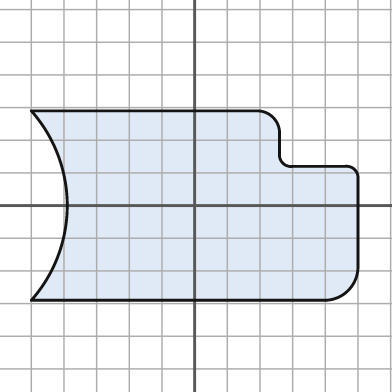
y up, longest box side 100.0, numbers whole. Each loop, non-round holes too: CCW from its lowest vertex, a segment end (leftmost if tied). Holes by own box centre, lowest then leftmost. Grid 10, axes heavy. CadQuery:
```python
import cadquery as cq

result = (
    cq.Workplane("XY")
    .moveTo(-50.0, -29.0)
    .lineTo(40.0, -29.0)
    .threePointArc((47.0, -26.0), (50.0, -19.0))
    .lineTo(50.0, 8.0)
    .threePointArc((49.0, 11.0), (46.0, 12.0))
    .lineTo(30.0, 12.0)
    .threePointArc((27.0, 13.0), (26.0, 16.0))
    .lineTo(26.0, 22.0)
    .threePointArc((24.0, 27.0), (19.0, 29.0))
    .lineTo(-50.0, 29.0)
    .threePointArc((-39.0, 0.0), (-50.0, -29.0))
    .close()
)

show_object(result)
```